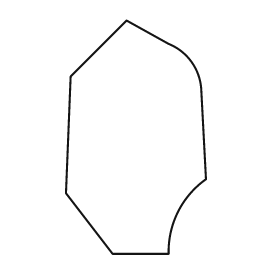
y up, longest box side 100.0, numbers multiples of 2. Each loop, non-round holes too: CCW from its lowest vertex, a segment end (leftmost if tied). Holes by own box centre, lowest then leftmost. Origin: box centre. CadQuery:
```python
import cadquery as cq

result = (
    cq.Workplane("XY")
    .moveTo(-10.0, -50.0)
    .lineTo(14.0, -50.0)
    .threePointArc((18.0, -32.0), (30.0, -18.0))
    .lineTo(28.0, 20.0)
    .threePointArc((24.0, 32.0), (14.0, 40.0))
    .lineTo(-4.0, 50.0)
    .lineTo(-28.0, 26.0)
    .lineTo(-30.0, -24.0)
    .close()
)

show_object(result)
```